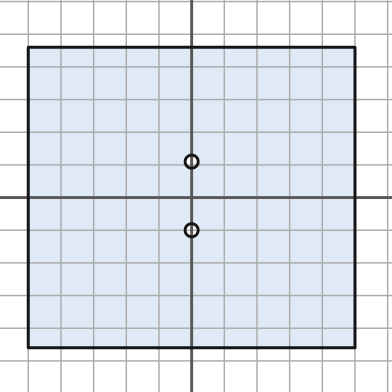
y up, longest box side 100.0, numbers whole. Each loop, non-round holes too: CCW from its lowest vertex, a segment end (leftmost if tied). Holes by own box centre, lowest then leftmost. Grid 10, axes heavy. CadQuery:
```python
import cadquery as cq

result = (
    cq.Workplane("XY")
    .moveTo(-50.0, -46.0)
    .lineTo(50.0, -46.0)
    .lineTo(50.0, 46.0)
    .lineTo(-50.0, 46.0)
    .close()
    .moveTo(0.0, -10.0)
    .circle(2.0)
    .moveTo(0.0, 11.0)
    .circle(2.0)
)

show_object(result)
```